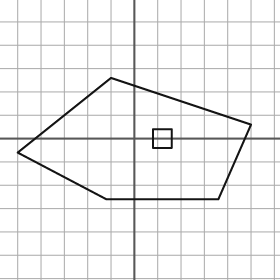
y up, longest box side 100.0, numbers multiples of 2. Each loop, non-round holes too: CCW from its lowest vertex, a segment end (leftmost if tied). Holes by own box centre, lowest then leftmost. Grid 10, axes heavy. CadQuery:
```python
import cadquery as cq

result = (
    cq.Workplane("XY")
    .moveTo(-12.0, -26.0)
    .lineTo(36.0, -26.0)
    .lineTo(50.0, 6.0)
    .lineTo(-10.0, 26.0)
    .lineTo(-50.0, -6.0)
    .close()
    .moveTo(8.0, -4.0)
    .lineTo(16.0, -4.0)
    .lineTo(16.0, 4.0)
    .lineTo(8.0, 4.0)
    .close()
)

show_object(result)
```